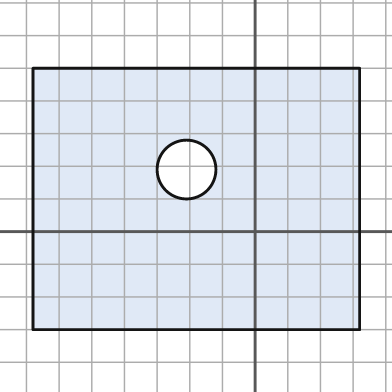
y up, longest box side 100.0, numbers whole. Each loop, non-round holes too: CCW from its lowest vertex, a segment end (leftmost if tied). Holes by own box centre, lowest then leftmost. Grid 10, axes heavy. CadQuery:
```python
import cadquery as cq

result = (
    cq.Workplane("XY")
    .moveTo(-68.0, -30.0)
    .lineTo(32.0, -30.0)
    .lineTo(32.0, 50.0)
    .lineTo(-68.0, 50.0)
    .close()
    .moveTo(-21.0, 19.0)
    .circle(9.0)
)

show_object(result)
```